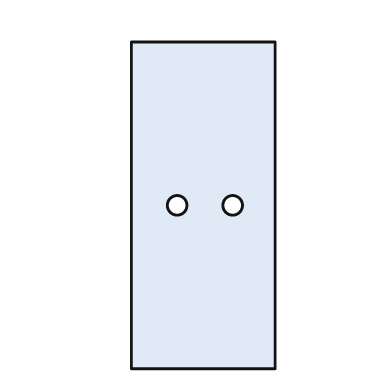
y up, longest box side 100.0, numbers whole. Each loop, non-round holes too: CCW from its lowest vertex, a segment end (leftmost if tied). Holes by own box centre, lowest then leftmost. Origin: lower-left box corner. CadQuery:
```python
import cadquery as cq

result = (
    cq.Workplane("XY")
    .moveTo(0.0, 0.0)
    .lineTo(44.0, 0.0)
    .lineTo(44.0, 100.0)
    .lineTo(0.0, 100.0)
    .close()
    .moveTo(14.0, 50.0)
    .circle(3.0)
    .moveTo(31.0, 50.0)
    .circle(3.0)
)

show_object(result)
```